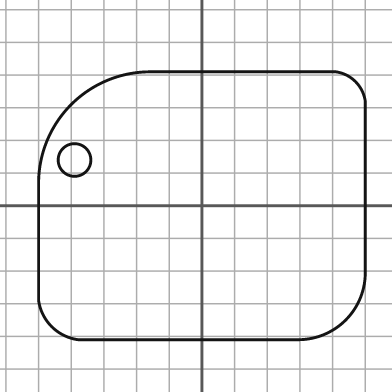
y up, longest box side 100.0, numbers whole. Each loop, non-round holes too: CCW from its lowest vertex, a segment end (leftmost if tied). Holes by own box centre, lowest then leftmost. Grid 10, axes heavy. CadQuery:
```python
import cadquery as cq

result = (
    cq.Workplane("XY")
    .moveTo(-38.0, -41.0)
    .lineTo(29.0, -41.0)
    .threePointArc((44.0, -35.0), (50.0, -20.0))
    .lineTo(50.0, 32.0)
    .threePointArc((47.0, 38.0), (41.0, 41.0))
    .lineTo(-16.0, 41.0)
    .threePointArc((-40.0, 31.0), (-50.0, 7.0))
    .lineTo(-50.0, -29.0)
    .threePointArc((-46.0, -37.0), (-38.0, -41.0))
    .close()
    .moveTo(-39.0, 14.0)
    .circle(5.0)
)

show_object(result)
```